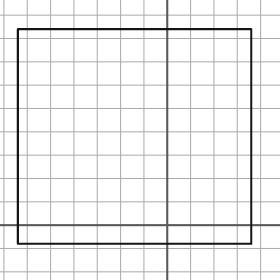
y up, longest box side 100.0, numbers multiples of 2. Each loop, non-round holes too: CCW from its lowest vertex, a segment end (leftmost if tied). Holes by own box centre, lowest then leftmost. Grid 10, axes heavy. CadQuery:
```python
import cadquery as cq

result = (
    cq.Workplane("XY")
    .moveTo(-64.0, -8.0)
    .lineTo(36.0, -8.0)
    .lineTo(36.0, 84.0)
    .lineTo(-64.0, 84.0)
    .close()
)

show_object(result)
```